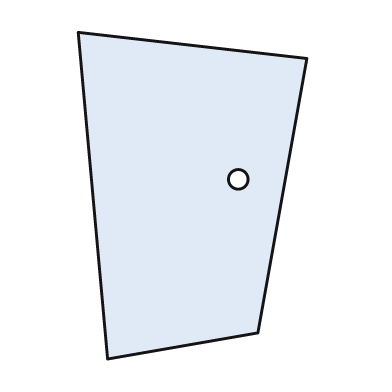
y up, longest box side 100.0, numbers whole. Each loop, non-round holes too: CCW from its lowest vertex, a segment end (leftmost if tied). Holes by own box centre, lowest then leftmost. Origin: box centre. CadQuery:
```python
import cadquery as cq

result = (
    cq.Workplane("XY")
    .moveTo(-26.0, -50.0)
    .lineTo(20.0, -42.0)
    .lineTo(35.0, 42.0)
    .lineTo(-35.0, 50.0)
    .close()
    .moveTo(14.0, 5.0)
    .circle(3.0)
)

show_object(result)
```